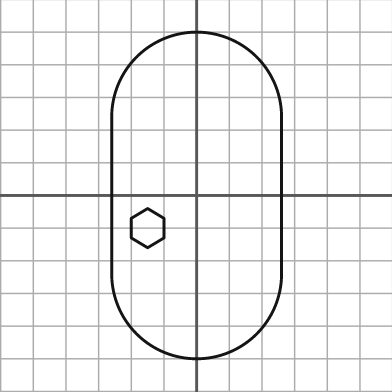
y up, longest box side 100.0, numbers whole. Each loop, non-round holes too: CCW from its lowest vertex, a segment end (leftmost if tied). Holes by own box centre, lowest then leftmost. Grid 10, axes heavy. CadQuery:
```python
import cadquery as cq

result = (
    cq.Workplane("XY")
    .moveTo(-26.0, -24.0)
    .threePointArc((0.0, -50.0), (26.0, -24.0))
    .lineTo(26.0, 24.0)
    .threePointArc((0.0, 50.0), (-26.0, 24.0))
    .close()
    .moveTo(-15.0, -16.0)
    .lineTo(-10.0, -13.0)
    .lineTo(-10.0, -7.0)
    .lineTo(-15.0, -4.0)
    .lineTo(-20.0, -7.0)
    .lineTo(-20.0, -13.0)
    .close()
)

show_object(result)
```